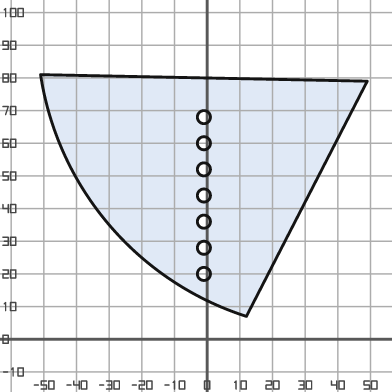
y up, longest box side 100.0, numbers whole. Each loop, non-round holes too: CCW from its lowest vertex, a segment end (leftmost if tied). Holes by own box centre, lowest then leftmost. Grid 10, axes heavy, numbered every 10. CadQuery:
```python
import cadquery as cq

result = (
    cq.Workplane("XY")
    .moveTo(12.0, 7.0)
    .lineTo(49.0, 79.0)
    .lineTo(-51.0, 81.0)
    .threePointArc((-30.0, 35.0), (12.0, 7.0))
    .close()
    .moveTo(-1.0, 20.0)
    .circle(2.0)
    .moveTo(-1.0, 28.0)
    .circle(2.0)
    .moveTo(-1.0, 36.0)
    .circle(2.0)
    .moveTo(-1.0, 44.0)
    .circle(2.0)
    .moveTo(-1.0, 52.0)
    .circle(2.0)
    .moveTo(-1.0, 60.0)
    .circle(2.0)
    .moveTo(-1.0, 68.0)
    .circle(2.0)
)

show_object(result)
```